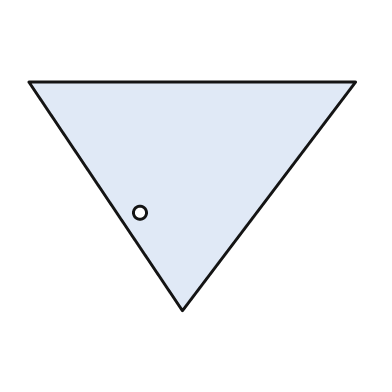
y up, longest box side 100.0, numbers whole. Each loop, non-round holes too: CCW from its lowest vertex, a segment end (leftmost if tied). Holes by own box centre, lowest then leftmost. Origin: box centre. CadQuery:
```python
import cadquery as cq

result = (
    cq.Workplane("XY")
    .moveTo(-3.0, -35.0)
    .lineTo(50.0, 35.0)
    .lineTo(-50.0, 35.0)
    .close()
    .moveTo(-16.0, -5.0)
    .circle(2.0)
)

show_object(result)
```